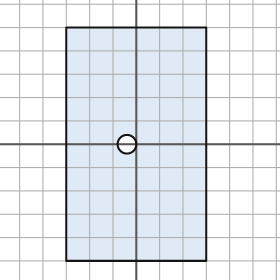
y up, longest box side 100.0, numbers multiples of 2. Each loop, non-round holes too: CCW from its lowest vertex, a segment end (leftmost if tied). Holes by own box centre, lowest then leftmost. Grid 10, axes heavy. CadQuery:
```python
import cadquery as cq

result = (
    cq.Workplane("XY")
    .moveTo(-30.0, -50.0)
    .lineTo(30.0, -50.0)
    .lineTo(30.0, 50.0)
    .lineTo(-30.0, 50.0)
    .close()
    .moveTo(-4.0, 0.0)
    .circle(4.0)
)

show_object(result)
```